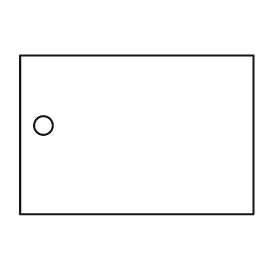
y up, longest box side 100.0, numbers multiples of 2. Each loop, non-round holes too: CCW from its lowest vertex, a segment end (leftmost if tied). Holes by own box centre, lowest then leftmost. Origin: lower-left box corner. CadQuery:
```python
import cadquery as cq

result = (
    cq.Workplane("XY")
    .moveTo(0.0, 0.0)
    .lineTo(100.0, 0.0)
    .lineTo(100.0, 68.0)
    .lineTo(0.0, 68.0)
    .close()
    .moveTo(10.0, 38.0)
    .circle(4.0)
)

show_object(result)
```